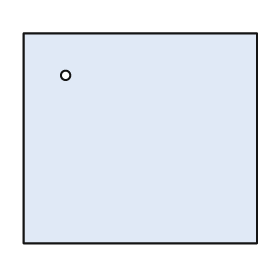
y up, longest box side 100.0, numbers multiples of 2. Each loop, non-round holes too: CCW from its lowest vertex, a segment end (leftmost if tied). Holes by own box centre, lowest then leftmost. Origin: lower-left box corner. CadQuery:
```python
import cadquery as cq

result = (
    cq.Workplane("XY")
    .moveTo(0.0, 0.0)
    .lineTo(100.0, 0.0)
    .lineTo(100.0, 90.0)
    .lineTo(0.0, 90.0)
    .close()
    .moveTo(18.0, 72.0)
    .circle(2.0)
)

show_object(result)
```